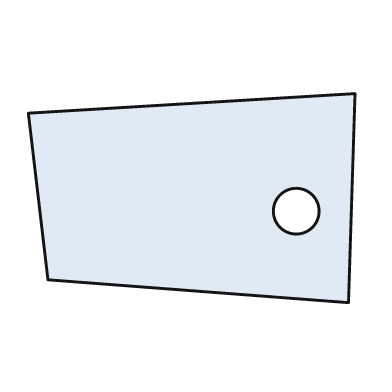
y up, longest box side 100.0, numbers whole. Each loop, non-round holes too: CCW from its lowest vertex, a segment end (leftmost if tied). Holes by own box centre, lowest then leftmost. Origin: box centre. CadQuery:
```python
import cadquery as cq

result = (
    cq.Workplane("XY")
    .moveTo(48.0, -32.0)
    .lineTo(50.0, 32.0)
    .lineTo(-50.0, 26.0)
    .lineTo(-44.0, -25.0)
    .close()
    .moveTo(32.0, -4.0)
    .circle(7.0)
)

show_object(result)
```